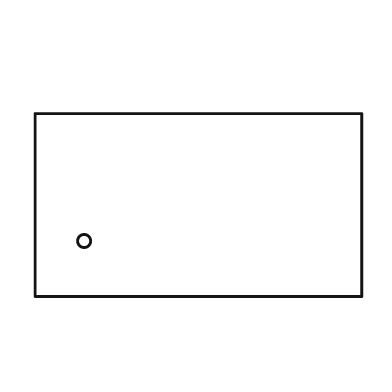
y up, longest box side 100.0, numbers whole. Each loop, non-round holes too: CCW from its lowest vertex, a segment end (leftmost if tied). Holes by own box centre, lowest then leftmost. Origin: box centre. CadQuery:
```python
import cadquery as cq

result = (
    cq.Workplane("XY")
    .moveTo(-50.0, -28.0)
    .lineTo(50.0, -28.0)
    .lineTo(50.0, 28.0)
    .lineTo(-50.0, 28.0)
    .close()
    .moveTo(-35.0, -11.0)
    .circle(2.0)
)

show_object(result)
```